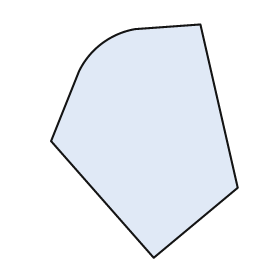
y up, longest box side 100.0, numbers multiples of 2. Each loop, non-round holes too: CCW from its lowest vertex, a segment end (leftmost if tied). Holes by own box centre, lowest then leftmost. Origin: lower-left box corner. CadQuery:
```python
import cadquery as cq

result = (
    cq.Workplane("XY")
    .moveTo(44.0, 0.0)
    .lineTo(80.0, 30.0)
    .lineTo(64.0, 100.0)
    .lineTo(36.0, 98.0)
    .threePointArc((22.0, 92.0), (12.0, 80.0))
    .lineTo(0.0, 50.0)
    .close()
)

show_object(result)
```